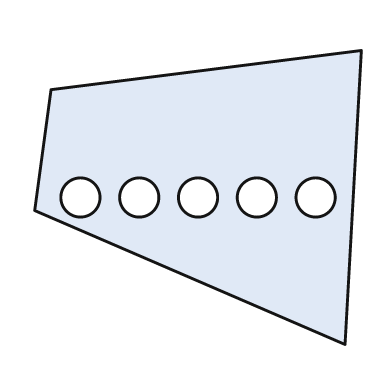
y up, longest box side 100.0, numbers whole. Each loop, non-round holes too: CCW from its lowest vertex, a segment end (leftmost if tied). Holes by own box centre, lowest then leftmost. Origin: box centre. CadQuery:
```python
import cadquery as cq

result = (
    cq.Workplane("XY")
    .moveTo(45.0, -45.0)
    .lineTo(50.0, 45.0)
    .lineTo(-45.0, 33.0)
    .lineTo(-50.0, -4.0)
    .close()
    .moveTo(-36.0, 0.0)
    .circle(6.0)
    .moveTo(-18.0, 0.0)
    .circle(6.0)
    .moveTo(0.0, 0.0)
    .circle(6.0)
    .moveTo(18.0, 0.0)
    .circle(6.0)
    .moveTo(36.0, 0.0)
    .circle(6.0)
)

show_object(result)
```